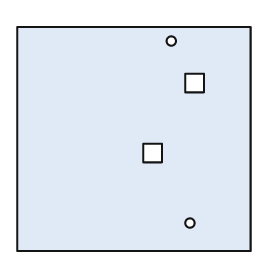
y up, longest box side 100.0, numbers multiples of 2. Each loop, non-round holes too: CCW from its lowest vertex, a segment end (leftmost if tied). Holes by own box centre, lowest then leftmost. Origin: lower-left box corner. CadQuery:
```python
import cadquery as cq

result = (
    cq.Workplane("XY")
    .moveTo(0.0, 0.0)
    .lineTo(100.0, 0.0)
    .lineTo(100.0, 96.0)
    .lineTo(0.0, 96.0)
    .close()
    .moveTo(74.0, 12.0)
    .circle(2.0)
    .moveTo(54.0, 38.0)
    .lineTo(62.0, 38.0)
    .lineTo(62.0, 46.0)
    .lineTo(54.0, 46.0)
    .close()
    .moveTo(72.0, 68.0)
    .lineTo(80.0, 68.0)
    .lineTo(80.0, 76.0)
    .lineTo(72.0, 76.0)
    .close()
    .moveTo(66.0, 90.0)
    .circle(2.0)
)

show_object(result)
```